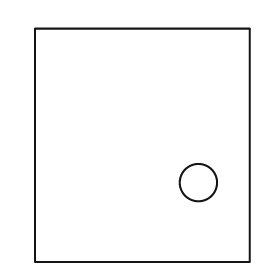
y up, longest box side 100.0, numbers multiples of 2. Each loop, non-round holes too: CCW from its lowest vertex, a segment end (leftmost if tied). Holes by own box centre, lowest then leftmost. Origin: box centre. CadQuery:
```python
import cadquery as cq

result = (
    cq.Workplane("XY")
    .moveTo(-46.0, -50.0)
    .lineTo(46.0, -50.0)
    .lineTo(46.0, 50.0)
    .lineTo(-46.0, 50.0)
    .close()
    .moveTo(24.0, -16.0)
    .circle(8.0)
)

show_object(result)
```